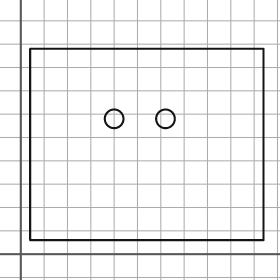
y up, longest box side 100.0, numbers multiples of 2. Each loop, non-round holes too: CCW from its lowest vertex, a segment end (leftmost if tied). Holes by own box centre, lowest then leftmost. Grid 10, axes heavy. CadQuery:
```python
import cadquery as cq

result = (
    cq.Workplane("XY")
    .moveTo(4.0, 6.0)
    .lineTo(104.0, 6.0)
    .lineTo(104.0, 88.0)
    .lineTo(4.0, 88.0)
    .close()
    .moveTo(40.0, 58.0)
    .circle(4.0)
    .moveTo(62.0, 58.0)
    .circle(4.0)
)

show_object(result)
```